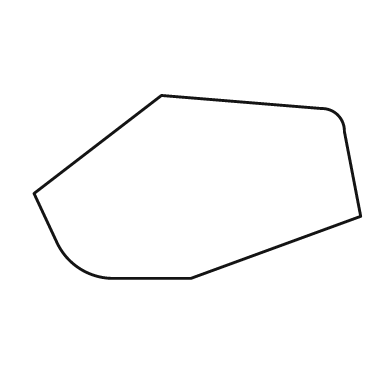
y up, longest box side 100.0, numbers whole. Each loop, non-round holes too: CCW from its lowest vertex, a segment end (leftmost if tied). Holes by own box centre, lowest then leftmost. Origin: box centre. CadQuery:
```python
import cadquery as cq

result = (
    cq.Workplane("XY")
    .moveTo(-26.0, -28.0)
    .lineTo(-2.0, -28.0)
    .lineTo(50.0, -9.0)
    .lineTo(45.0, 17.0)
    .threePointArc((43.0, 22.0), (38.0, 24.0))
    .lineTo(-11.0, 28.0)
    .lineTo(-50.0, -2.0)
    .lineTo(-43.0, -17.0)
    .threePointArc((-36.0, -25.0), (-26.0, -28.0))
    .close()
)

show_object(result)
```